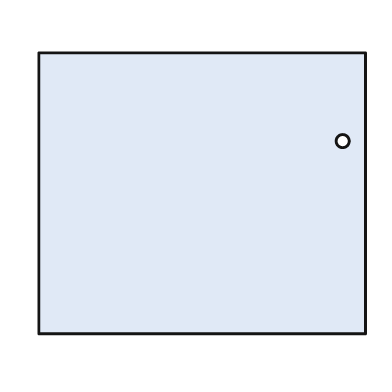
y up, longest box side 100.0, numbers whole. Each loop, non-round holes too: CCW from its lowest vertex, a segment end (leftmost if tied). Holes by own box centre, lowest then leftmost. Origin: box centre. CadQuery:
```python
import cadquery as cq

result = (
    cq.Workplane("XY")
    .moveTo(-50.0, -43.0)
    .lineTo(50.0, -43.0)
    .lineTo(50.0, 43.0)
    .lineTo(-50.0, 43.0)
    .close()
    .moveTo(43.0, 16.0)
    .circle(2.0)
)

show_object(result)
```